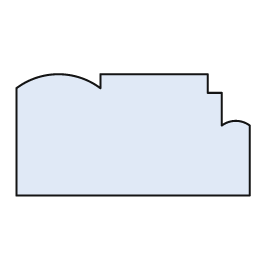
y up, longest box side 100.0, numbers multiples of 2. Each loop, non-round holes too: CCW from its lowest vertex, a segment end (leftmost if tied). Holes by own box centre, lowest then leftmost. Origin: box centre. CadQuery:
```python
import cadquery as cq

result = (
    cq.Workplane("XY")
    .moveTo(-50.0, -26.0)
    .lineTo(50.0, -26.0)
    .lineTo(50.0, 4.0)
    .threePointArc((44.0, 6.0), (38.0, 4.0))
    .lineTo(38.0, 18.0)
    .lineTo(32.0, 18.0)
    .lineTo(32.0, 26.0)
    .lineTo(-14.0, 26.0)
    .lineTo(-14.0, 20.0)
    .threePointArc((-32.0, 26.0), (-50.0, 20.0))
    .close()
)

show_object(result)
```